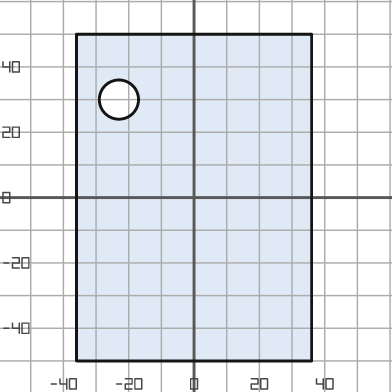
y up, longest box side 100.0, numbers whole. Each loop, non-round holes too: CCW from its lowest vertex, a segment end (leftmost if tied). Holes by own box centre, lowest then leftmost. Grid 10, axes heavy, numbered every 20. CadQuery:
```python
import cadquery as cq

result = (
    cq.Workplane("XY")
    .moveTo(-36.0, -50.0)
    .lineTo(36.0, -50.0)
    .lineTo(36.0, 50.0)
    .lineTo(-36.0, 50.0)
    .close()
    .moveTo(-23.0, 30.0)
    .circle(6.0)
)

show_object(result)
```